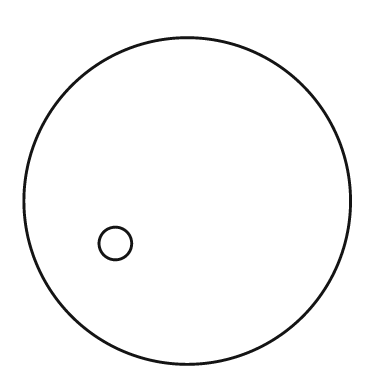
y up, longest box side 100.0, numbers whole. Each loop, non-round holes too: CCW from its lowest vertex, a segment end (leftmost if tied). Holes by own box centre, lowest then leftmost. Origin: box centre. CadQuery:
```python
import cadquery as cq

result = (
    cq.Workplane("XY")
    .moveTo(0.0, 0.0)
    .circle(50.0)
    .moveTo(-22.0, -13.0)
    .circle(5.0)
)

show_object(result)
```